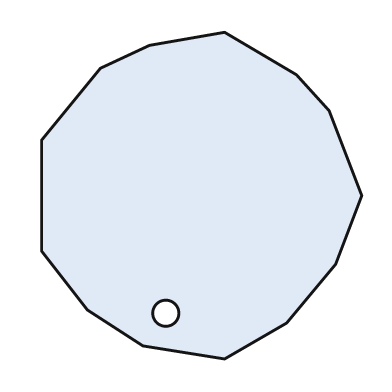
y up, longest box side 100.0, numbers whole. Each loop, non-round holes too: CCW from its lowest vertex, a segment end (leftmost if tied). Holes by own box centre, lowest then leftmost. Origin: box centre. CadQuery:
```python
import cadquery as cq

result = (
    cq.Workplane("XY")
    .moveTo(7.0, -50.0)
    .lineTo(26.0, -39.0)
    .lineTo(41.0, -21.0)
    .lineTo(49.0, 0.0)
    .lineTo(39.0, 26.0)
    .lineTo(29.0, 37.0)
    .lineTo(7.0, 50.0)
    .lineTo(-16.0, 46.0)
    .lineTo(-31.0, 39.0)
    .lineTo(-49.0, 17.0)
    .lineTo(-49.0, -17.0)
    .lineTo(-35.0, -35.0)
    .lineTo(-18.0, -46.0)
    .close()
    .moveTo(-11.0, -36.0)
    .circle(4.0)
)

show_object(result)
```